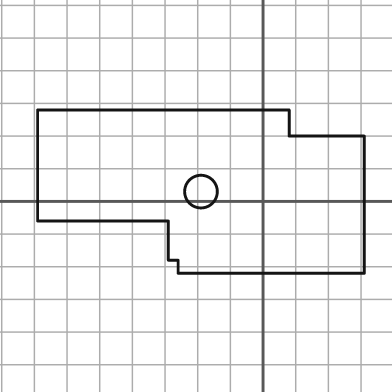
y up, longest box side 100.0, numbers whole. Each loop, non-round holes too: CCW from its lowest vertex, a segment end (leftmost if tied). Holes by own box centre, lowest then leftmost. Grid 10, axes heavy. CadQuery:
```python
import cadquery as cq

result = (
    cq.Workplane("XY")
    .moveTo(-26.0, -22.0)
    .lineTo(31.0, -22.0)
    .lineTo(31.0, 20.0)
    .lineTo(8.0, 20.0)
    .lineTo(8.0, 28.0)
    .lineTo(-69.0, 28.0)
    .lineTo(-69.0, -6.0)
    .lineTo(-29.0, -6.0)
    .lineTo(-29.0, -18.0)
    .lineTo(-26.0, -18.0)
    .close()
    .moveTo(-19.0, 3.0)
    .circle(5.0)
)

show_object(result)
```